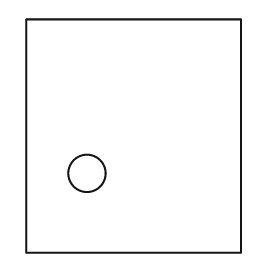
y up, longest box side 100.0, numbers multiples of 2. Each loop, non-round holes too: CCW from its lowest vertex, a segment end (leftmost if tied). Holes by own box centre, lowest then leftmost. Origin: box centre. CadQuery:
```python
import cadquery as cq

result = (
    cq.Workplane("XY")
    .moveTo(-46.0, -50.0)
    .lineTo(46.0, -50.0)
    .lineTo(46.0, 50.0)
    .lineTo(-46.0, 50.0)
    .close()
    .moveTo(-20.0, -16.0)
    .circle(8.0)
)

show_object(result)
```